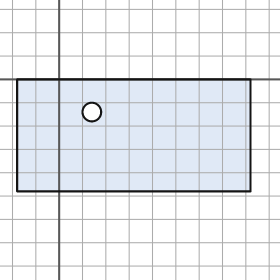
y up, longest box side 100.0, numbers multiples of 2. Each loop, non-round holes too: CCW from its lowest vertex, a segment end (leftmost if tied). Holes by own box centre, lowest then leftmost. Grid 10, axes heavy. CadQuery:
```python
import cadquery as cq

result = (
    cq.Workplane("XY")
    .moveTo(-18.0, -48.0)
    .lineTo(82.0, -48.0)
    .lineTo(82.0, 0.0)
    .lineTo(-18.0, 0.0)
    .close()
    .moveTo(14.0, -14.0)
    .circle(4.0)
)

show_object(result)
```